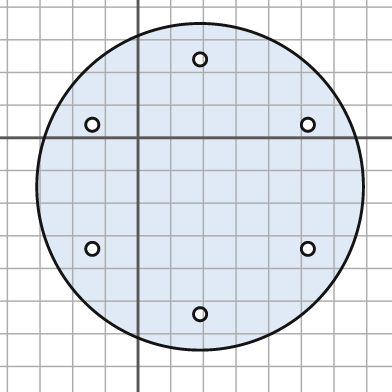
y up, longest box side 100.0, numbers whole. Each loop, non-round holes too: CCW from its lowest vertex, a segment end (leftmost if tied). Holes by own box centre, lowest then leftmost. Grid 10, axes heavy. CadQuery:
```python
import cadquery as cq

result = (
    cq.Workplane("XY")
    .moveTo(19.0, -15.0)
    .circle(50.0)
    .moveTo(19.0, -54.0)
    .circle(2.0)
    .moveTo(-14.0, -34.0)
    .circle(2.0)
    .moveTo(52.0, -34.0)
    .circle(2.0)
    .moveTo(-14.0, 4.0)
    .circle(2.0)
    .moveTo(52.0, 4.0)
    .circle(2.0)
    .moveTo(19.0, 24.0)
    .circle(2.0)
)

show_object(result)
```